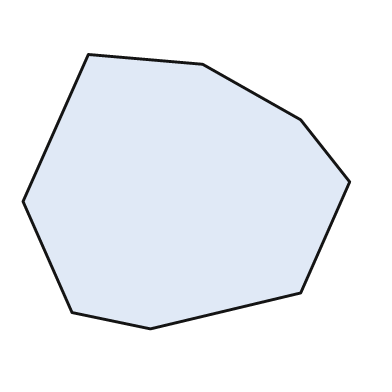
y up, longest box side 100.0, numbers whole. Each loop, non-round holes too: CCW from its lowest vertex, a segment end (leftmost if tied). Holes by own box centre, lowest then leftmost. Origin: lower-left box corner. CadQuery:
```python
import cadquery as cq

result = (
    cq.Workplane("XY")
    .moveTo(39.0, 0.0)
    .lineTo(85.0, 11.0)
    .lineTo(100.0, 45.0)
    .lineTo(85.0, 64.0)
    .lineTo(55.0, 81.0)
    .lineTo(20.0, 84.0)
    .lineTo(0.0, 39.0)
    .lineTo(15.0, 5.0)
    .close()
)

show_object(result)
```